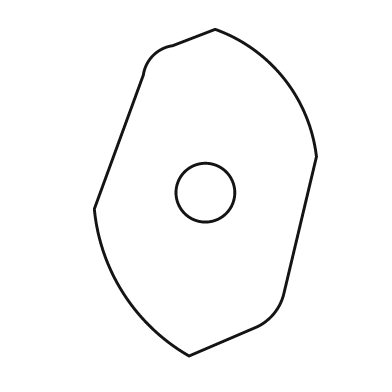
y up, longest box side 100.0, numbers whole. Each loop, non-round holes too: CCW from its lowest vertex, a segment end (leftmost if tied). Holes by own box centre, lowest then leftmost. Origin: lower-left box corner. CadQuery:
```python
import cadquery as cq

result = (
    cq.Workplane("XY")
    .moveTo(29.0, 0.0)
    .lineTo(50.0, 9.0)
    .threePointArc((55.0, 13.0), (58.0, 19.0))
    .lineTo(68.0, 61.0)
    .threePointArc((58.0, 85.0), (37.0, 100.0))
    .lineTo(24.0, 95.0)
    .threePointArc((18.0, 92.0), (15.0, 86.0))
    .lineTo(0.0, 45.0)
    .threePointArc((9.0, 19.0), (29.0, 0.0))
    .close()
    .moveTo(34.0, 50.0)
    .circle(9.0)
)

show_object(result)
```